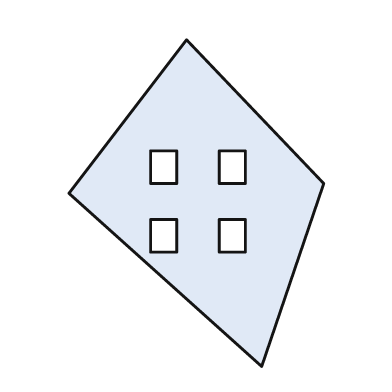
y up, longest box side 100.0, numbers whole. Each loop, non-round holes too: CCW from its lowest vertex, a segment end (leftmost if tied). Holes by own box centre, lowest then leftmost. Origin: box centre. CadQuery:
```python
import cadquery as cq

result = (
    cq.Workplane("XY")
    .moveTo(20.0, -50.0)
    .lineTo(39.0, 6.0)
    .lineTo(-3.0, 50.0)
    .lineTo(-39.0, 3.0)
    .close()
    .moveTo(-14.0, -15.0)
    .lineTo(-6.0, -15.0)
    .lineTo(-6.0, -5.0)
    .lineTo(-14.0, -5.0)
    .close()
    .moveTo(7.0, -15.0)
    .lineTo(15.0, -15.0)
    .lineTo(15.0, -5.0)
    .lineTo(7.0, -5.0)
    .close()
    .moveTo(-14.0, 6.0)
    .lineTo(-6.0, 6.0)
    .lineTo(-6.0, 16.0)
    .lineTo(-14.0, 16.0)
    .close()
    .moveTo(7.0, 6.0)
    .lineTo(15.0, 6.0)
    .lineTo(15.0, 16.0)
    .lineTo(7.0, 16.0)
    .close()
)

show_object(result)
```